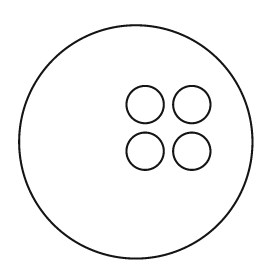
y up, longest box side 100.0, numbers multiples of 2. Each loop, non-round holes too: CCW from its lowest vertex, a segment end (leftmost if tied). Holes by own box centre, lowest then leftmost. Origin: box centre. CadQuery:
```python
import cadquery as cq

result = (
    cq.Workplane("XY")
    .moveTo(0.0, 0.0)
    .circle(50.0)
    .moveTo(4.0, -4.0)
    .circle(8.0)
    .moveTo(24.0, -4.0)
    .circle(8.0)
    .moveTo(4.0, 16.0)
    .circle(8.0)
    .moveTo(24.0, 16.0)
    .circle(8.0)
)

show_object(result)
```